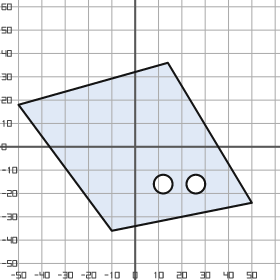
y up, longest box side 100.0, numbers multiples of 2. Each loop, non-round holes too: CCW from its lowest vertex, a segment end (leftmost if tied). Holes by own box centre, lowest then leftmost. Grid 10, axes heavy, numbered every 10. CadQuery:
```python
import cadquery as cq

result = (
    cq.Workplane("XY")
    .moveTo(-10.0, -36.0)
    .lineTo(50.0, -24.0)
    .lineTo(14.0, 36.0)
    .lineTo(-50.0, 18.0)
    .close()
    .moveTo(12.0, -16.0)
    .circle(4.0)
    .moveTo(26.0, -16.0)
    .circle(4.0)
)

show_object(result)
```